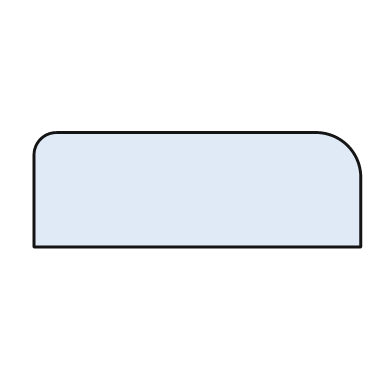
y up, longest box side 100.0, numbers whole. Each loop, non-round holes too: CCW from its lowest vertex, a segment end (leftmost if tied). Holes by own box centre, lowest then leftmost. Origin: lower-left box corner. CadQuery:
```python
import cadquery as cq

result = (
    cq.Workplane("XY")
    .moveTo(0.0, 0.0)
    .lineTo(100.0, 0.0)
    .lineTo(100.0, 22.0)
    .threePointArc((96.0, 31.0), (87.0, 35.0))
    .lineTo(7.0, 35.0)
    .threePointArc((2.0, 33.0), (0.0, 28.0))
    .close()
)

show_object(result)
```